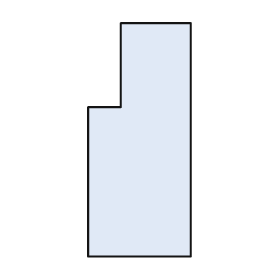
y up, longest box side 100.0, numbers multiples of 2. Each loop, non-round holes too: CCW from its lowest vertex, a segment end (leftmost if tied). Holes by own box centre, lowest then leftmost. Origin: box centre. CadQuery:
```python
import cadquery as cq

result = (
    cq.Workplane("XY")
    .moveTo(-22.0, -50.0)
    .lineTo(22.0, -50.0)
    .lineTo(22.0, 50.0)
    .lineTo(-8.0, 50.0)
    .lineTo(-8.0, 14.0)
    .lineTo(-22.0, 14.0)
    .close()
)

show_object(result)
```